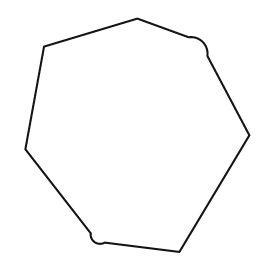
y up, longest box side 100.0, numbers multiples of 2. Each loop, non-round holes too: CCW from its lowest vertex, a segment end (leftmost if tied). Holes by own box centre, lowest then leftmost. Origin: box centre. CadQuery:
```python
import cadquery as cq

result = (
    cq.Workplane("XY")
    .moveTo(18.0, -50.0)
    .lineTo(48.0, 0.0)
    .lineTo(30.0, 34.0)
    .threePointArc((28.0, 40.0), (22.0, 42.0))
    .lineTo(0.0, 50.0)
    .lineTo(-40.0, 38.0)
    .lineTo(-48.0, -6.0)
    .lineTo(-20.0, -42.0)
    .threePointArc((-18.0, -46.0), (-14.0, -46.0))
    .close()
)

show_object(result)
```